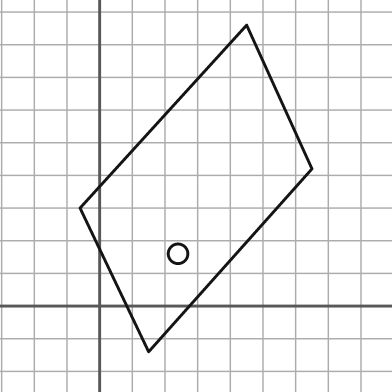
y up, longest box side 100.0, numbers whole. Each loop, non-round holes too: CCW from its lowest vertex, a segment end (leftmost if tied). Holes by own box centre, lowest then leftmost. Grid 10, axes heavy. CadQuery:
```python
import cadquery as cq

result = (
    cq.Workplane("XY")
    .moveTo(15.0, -14.0)
    .lineTo(65.0, 42.0)
    .lineTo(45.0, 86.0)
    .lineTo(-6.0, 30.0)
    .close()
    .moveTo(24.0, 16.0)
    .circle(3.0)
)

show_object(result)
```